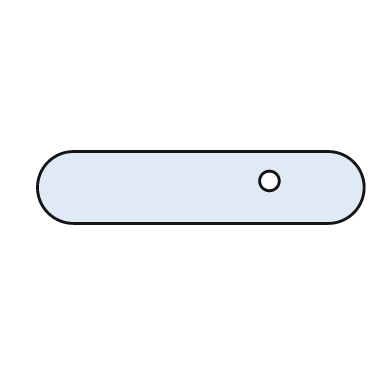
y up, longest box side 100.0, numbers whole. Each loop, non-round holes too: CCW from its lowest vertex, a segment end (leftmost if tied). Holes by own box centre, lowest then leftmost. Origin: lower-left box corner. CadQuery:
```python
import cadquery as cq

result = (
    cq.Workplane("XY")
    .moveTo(11.0, 0.0)
    .lineTo(89.0, 0.0)
    .threePointArc((100.0, 11.0), (89.0, 22.0))
    .lineTo(11.0, 22.0)
    .threePointArc((0.0, 11.0), (11.0, 0.0))
    .close()
    .moveTo(71.0, 13.0)
    .circle(3.0)
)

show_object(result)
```